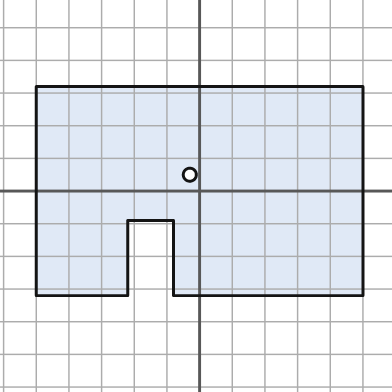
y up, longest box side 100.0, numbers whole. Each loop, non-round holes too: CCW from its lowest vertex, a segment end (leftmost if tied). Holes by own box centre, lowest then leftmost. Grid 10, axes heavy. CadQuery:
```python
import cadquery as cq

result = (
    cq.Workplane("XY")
    .moveTo(-50.0, -32.0)
    .lineTo(-22.0, -32.0)
    .lineTo(-22.0, -9.0)
    .lineTo(-8.0, -9.0)
    .lineTo(-8.0, -32.0)
    .lineTo(50.0, -32.0)
    .lineTo(50.0, 32.0)
    .lineTo(-50.0, 32.0)
    .close()
    .moveTo(-3.0, 5.0)
    .circle(2.0)
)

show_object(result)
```